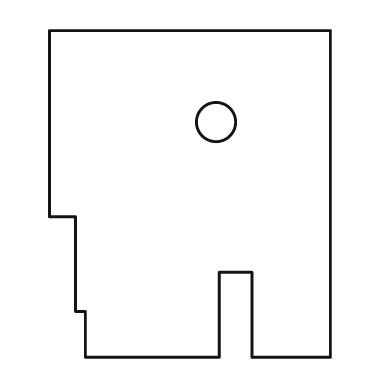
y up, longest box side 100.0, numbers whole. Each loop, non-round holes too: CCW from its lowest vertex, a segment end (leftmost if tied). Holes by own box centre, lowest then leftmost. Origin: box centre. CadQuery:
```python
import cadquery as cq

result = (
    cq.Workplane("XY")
    .moveTo(-32.0, -50.0)
    .lineTo(9.0, -50.0)
    .lineTo(9.0, -24.0)
    .lineTo(19.0, -24.0)
    .lineTo(19.0, -50.0)
    .lineTo(43.0, -50.0)
    .lineTo(43.0, 50.0)
    .lineTo(-43.0, 50.0)
    .lineTo(-43.0, -7.0)
    .lineTo(-35.0, -7.0)
    .lineTo(-35.0, -36.0)
    .lineTo(-32.0, -36.0)
    .close()
    .moveTo(8.0, 22.0)
    .circle(6.0)
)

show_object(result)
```